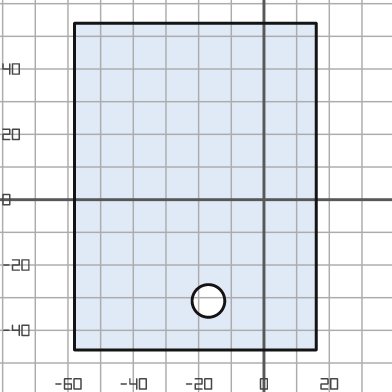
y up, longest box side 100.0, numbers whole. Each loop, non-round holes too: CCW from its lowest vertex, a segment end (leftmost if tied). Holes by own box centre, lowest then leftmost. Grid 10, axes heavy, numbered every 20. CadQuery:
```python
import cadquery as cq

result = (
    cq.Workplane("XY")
    .moveTo(-58.0, -46.0)
    .lineTo(16.0, -46.0)
    .lineTo(16.0, 54.0)
    .lineTo(-58.0, 54.0)
    .close()
    .moveTo(-17.0, -31.0)
    .circle(5.0)
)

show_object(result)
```